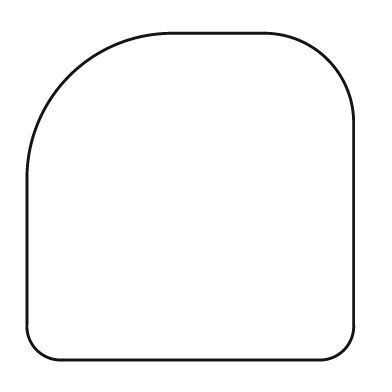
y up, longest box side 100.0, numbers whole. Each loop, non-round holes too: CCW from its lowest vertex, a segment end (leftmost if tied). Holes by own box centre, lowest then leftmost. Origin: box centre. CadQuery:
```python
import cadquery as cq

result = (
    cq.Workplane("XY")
    .moveTo(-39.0, -50.0)
    .lineTo(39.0, -50.0)
    .threePointArc((47.0, -47.0), (50.0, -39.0))
    .lineTo(50.0, 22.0)
    .threePointArc((42.0, 42.0), (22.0, 50.0))
    .lineTo(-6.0, 50.0)
    .threePointArc((-37.0, 37.0), (-50.0, 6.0))
    .lineTo(-50.0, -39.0)
    .threePointArc((-47.0, -47.0), (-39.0, -50.0))
    .close()
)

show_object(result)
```